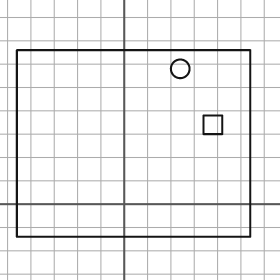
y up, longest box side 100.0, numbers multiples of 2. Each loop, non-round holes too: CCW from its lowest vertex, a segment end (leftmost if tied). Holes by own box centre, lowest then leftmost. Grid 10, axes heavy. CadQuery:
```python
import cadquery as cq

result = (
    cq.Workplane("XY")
    .moveTo(-46.0, -14.0)
    .lineTo(54.0, -14.0)
    .lineTo(54.0, 66.0)
    .lineTo(-46.0, 66.0)
    .close()
    .moveTo(34.0, 30.0)
    .lineTo(42.0, 30.0)
    .lineTo(42.0, 38.0)
    .lineTo(34.0, 38.0)
    .close()
    .moveTo(24.0, 58.0)
    .circle(4.0)
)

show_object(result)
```